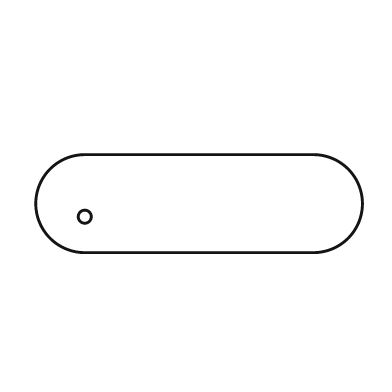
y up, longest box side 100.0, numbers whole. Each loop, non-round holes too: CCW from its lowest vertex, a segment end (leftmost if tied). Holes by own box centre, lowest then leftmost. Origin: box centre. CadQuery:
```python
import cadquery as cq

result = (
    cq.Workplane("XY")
    .moveTo(-35.0, -15.0)
    .lineTo(35.0, -15.0)
    .threePointArc((50.0, 0.0), (35.0, 15.0))
    .lineTo(-35.0, 15.0)
    .threePointArc((-50.0, 0.0), (-35.0, -15.0))
    .close()
    .moveTo(-35.0, -4.0)
    .circle(2.0)
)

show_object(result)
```